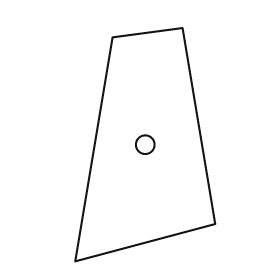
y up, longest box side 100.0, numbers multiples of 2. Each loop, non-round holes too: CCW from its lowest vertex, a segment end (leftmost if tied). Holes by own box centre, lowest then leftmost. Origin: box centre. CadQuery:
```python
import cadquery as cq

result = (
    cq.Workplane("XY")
    .moveTo(-30.0, -50.0)
    .lineTo(30.0, -34.0)
    .lineTo(16.0, 50.0)
    .lineTo(-14.0, 46.0)
    .close()
    .moveTo(0.0, 0.0)
    .circle(4.0)
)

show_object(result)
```